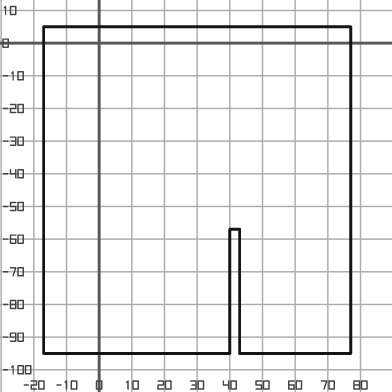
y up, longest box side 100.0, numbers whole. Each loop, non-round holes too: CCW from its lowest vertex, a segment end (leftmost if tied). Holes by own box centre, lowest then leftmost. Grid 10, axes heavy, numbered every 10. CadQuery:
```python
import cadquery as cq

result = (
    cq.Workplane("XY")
    .moveTo(-17.0, -95.0)
    .lineTo(40.0, -95.0)
    .lineTo(40.0, -57.0)
    .lineTo(43.0, -57.0)
    .lineTo(43.0, -95.0)
    .lineTo(77.0, -95.0)
    .lineTo(77.0, 5.0)
    .lineTo(-17.0, 5.0)
    .close()
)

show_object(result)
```